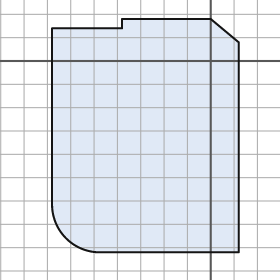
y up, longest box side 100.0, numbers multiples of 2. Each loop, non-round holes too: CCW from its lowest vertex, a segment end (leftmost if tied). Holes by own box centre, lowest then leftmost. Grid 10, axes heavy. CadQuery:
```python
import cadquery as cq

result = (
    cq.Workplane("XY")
    .moveTo(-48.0, -82.0)
    .lineTo(12.0, -82.0)
    .lineTo(12.0, 8.0)
    .lineTo(0.0, 18.0)
    .lineTo(-38.0, 18.0)
    .lineTo(-38.0, 14.0)
    .lineTo(-68.0, 14.0)
    .lineTo(-68.0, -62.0)
    .threePointArc((-62.0, -76.0), (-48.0, -82.0))
    .close()
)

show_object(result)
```